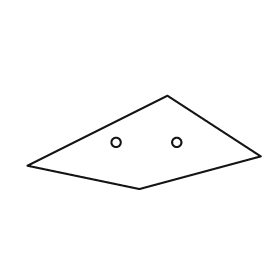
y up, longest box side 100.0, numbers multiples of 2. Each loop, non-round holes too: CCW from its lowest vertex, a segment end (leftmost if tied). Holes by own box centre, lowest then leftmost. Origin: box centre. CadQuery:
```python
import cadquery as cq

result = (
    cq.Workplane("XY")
    .moveTo(-2.0, -20.0)
    .lineTo(50.0, -6.0)
    .lineTo(10.0, 20.0)
    .lineTo(-50.0, -10.0)
    .close()
    .moveTo(-12.0, 0.0)
    .circle(2.0)
    .moveTo(14.0, 0.0)
    .circle(2.0)
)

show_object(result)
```